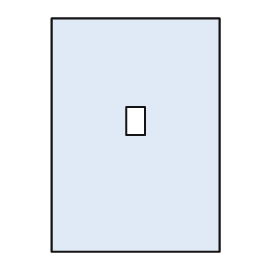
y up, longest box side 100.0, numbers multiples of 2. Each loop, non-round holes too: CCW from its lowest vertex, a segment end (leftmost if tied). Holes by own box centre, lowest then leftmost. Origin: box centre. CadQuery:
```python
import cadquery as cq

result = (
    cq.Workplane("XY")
    .moveTo(-36.0, -50.0)
    .lineTo(36.0, -50.0)
    .lineTo(36.0, 50.0)
    .lineTo(-36.0, 50.0)
    .close()
    .moveTo(-4.0, 0.0)
    .lineTo(4.0, 0.0)
    .lineTo(4.0, 12.0)
    .lineTo(-4.0, 12.0)
    .close()
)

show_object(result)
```